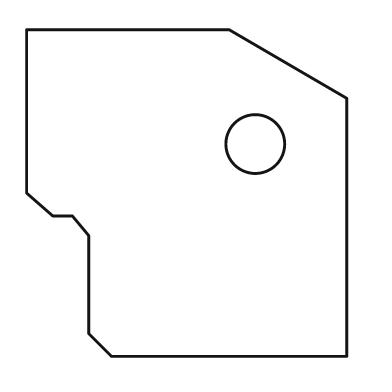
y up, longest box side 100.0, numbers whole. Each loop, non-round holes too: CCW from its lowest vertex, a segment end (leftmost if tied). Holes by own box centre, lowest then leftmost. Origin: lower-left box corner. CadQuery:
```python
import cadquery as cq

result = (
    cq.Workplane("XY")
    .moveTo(26.0, 0.0)
    .lineTo(98.0, 0.0)
    .lineTo(98.0, 79.0)
    .lineTo(62.0, 100.0)
    .lineTo(0.0, 100.0)
    .lineTo(0.0, 50.0)
    .lineTo(8.0, 43.0)
    .lineTo(14.0, 43.0)
    .lineTo(19.0, 37.0)
    .lineTo(19.0, 7.0)
    .close()
    .moveTo(70.0, 65.0)
    .circle(9.0)
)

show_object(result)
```